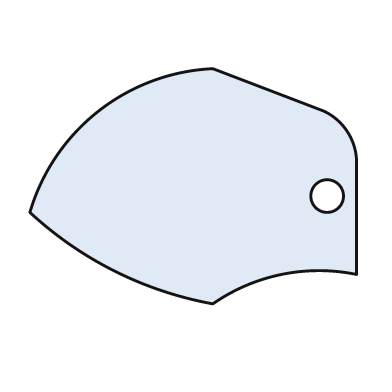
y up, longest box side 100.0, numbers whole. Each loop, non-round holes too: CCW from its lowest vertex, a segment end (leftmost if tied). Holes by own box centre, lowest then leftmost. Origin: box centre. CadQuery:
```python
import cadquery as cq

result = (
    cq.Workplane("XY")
    .moveTo(6.0, -36.0)
    .threePointArc((27.0, -27.0), (50.0, -27.0))
    .lineTo(50.0, 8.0)
    .threePointArc((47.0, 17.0), (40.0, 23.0))
    .lineTo(6.0, 36.0)
    .threePointArc((-29.0, 23.0), (-50.0, -8.0))
    .threePointArc((-24.0, -26.0), (6.0, -36.0))
    .close()
    .moveTo(41.0, -3.0)
    .circle(5.0)
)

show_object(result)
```